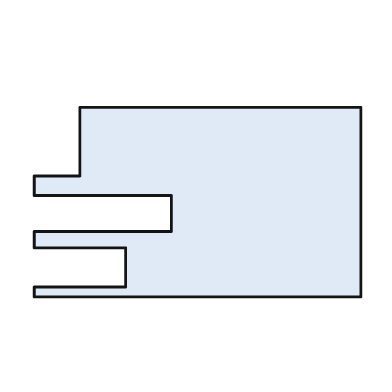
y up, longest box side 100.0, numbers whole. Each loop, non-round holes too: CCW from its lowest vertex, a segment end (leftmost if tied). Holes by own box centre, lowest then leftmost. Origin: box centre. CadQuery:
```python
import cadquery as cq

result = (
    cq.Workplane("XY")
    .moveTo(-50.0, -29.0)
    .lineTo(50.0, -29.0)
    .lineTo(50.0, 29.0)
    .lineTo(-36.0, 29.0)
    .lineTo(-36.0, 8.0)
    .lineTo(-50.0, 8.0)
    .lineTo(-50.0, 2.0)
    .lineTo(-8.0, 2.0)
    .lineTo(-8.0, -9.0)
    .lineTo(-50.0, -9.0)
    .lineTo(-50.0, -14.0)
    .lineTo(-22.0, -14.0)
    .lineTo(-22.0, -26.0)
    .lineTo(-50.0, -26.0)
    .close()
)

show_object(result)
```